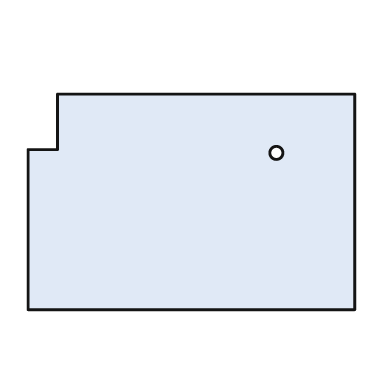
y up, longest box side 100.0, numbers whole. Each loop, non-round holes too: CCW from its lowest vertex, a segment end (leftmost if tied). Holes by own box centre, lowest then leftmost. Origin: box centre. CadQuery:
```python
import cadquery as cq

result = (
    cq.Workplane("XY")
    .moveTo(-50.0, -33.0)
    .lineTo(50.0, -33.0)
    .lineTo(50.0, 33.0)
    .lineTo(-41.0, 33.0)
    .lineTo(-41.0, 16.0)
    .lineTo(-50.0, 16.0)
    .close()
    .moveTo(26.0, 15.0)
    .circle(2.0)
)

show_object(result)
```